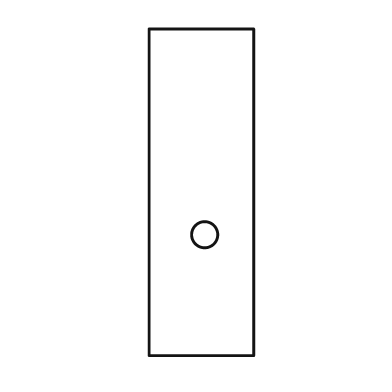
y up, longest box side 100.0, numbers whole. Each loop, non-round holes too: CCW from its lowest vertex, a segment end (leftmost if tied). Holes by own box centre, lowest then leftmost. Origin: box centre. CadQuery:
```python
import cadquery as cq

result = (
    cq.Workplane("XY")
    .moveTo(-16.0, -50.0)
    .lineTo(16.0, -50.0)
    .lineTo(16.0, 50.0)
    .lineTo(-16.0, 50.0)
    .close()
    .moveTo(1.0, -13.0)
    .circle(4.0)
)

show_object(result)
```